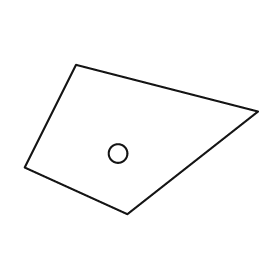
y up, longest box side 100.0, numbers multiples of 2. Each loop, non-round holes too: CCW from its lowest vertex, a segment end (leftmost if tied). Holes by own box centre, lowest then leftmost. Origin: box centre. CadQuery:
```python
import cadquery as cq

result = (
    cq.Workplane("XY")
    .moveTo(-6.0, -32.0)
    .lineTo(50.0, 12.0)
    .lineTo(-28.0, 32.0)
    .lineTo(-50.0, -12.0)
    .close()
    .moveTo(-10.0, -6.0)
    .circle(4.0)
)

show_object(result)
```